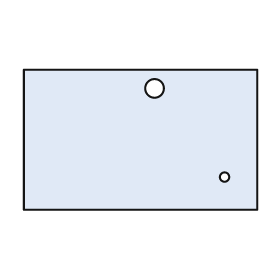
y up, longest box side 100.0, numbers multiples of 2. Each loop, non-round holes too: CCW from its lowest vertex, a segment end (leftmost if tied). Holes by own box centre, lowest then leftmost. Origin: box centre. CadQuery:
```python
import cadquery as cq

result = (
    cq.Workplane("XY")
    .moveTo(-50.0, -30.0)
    .lineTo(50.0, -30.0)
    .lineTo(50.0, 30.0)
    .lineTo(-50.0, 30.0)
    .close()
    .moveTo(36.0, -16.0)
    .circle(2.0)
    .moveTo(6.0, 22.0)
    .circle(4.0)
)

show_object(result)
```